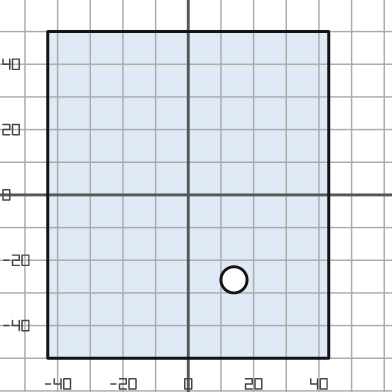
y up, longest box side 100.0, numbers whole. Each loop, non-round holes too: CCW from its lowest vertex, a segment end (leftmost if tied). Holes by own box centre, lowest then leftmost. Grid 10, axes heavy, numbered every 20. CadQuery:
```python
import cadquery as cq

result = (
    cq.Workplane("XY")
    .moveTo(-43.0, -50.0)
    .lineTo(43.0, -50.0)
    .lineTo(43.0, 50.0)
    .lineTo(-43.0, 50.0)
    .close()
    .moveTo(14.0, -26.0)
    .circle(4.0)
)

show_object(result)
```